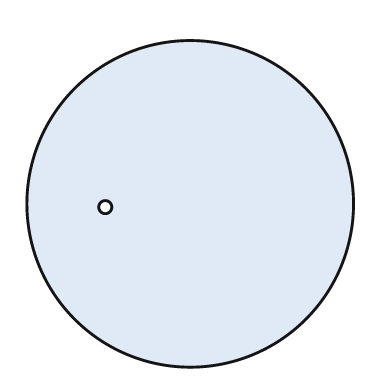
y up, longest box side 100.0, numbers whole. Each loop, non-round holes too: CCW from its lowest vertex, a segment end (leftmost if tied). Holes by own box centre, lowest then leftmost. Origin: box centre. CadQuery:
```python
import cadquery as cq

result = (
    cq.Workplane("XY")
    .moveTo(0.0, 0.0)
    .circle(50.0)
    .moveTo(-26.0, -1.0)
    .circle(2.0)
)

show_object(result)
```